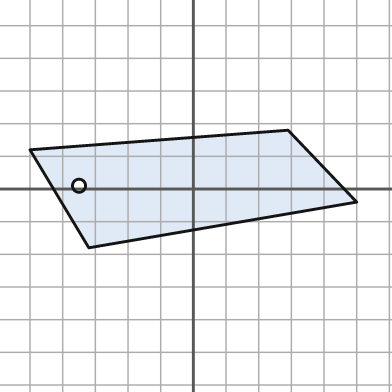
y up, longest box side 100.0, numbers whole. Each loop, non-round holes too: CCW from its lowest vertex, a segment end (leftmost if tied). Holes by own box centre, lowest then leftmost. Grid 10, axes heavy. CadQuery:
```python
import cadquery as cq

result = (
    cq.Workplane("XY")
    .moveTo(-32.0, -18.0)
    .lineTo(50.0, -4.0)
    .lineTo(29.0, 18.0)
    .lineTo(-50.0, 12.0)
    .close()
    .moveTo(-35.0, 1.0)
    .circle(2.0)
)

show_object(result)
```